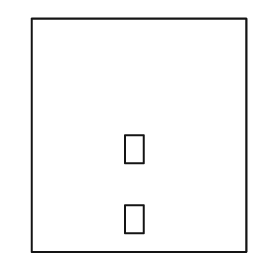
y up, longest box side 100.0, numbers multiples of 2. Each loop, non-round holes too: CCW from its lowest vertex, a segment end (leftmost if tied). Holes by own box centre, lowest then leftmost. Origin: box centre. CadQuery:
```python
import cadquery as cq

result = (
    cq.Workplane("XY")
    .moveTo(-46.0, -50.0)
    .lineTo(46.0, -50.0)
    .lineTo(46.0, 50.0)
    .lineTo(-46.0, 50.0)
    .close()
    .moveTo(-6.0, -42.0)
    .lineTo(2.0, -42.0)
    .lineTo(2.0, -30.0)
    .lineTo(-6.0, -30.0)
    .close()
    .moveTo(-6.0, -12.0)
    .lineTo(2.0, -12.0)
    .lineTo(2.0, 0.0)
    .lineTo(-6.0, 0.0)
    .close()
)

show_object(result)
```